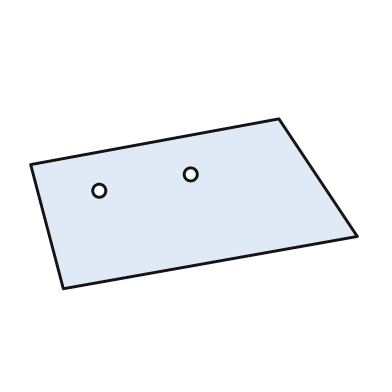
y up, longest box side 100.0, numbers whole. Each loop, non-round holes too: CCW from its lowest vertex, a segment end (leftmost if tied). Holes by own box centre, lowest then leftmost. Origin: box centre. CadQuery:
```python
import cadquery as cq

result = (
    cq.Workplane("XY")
    .moveTo(-40.0, -26.0)
    .lineTo(50.0, -10.0)
    .lineTo(26.0, 26.0)
    .lineTo(-50.0, 12.0)
    .close()
    .moveTo(-29.0, 4.0)
    .circle(2.0)
    .moveTo(-1.0, 9.0)
    .circle(2.0)
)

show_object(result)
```